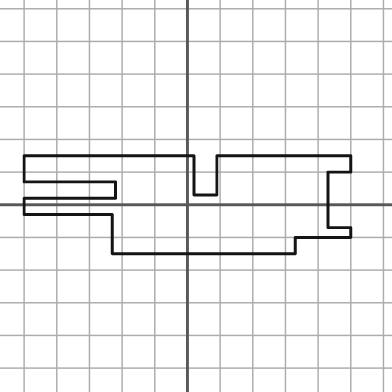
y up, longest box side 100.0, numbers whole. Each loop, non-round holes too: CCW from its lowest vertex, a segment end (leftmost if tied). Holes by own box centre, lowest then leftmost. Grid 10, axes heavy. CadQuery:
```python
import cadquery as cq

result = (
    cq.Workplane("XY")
    .moveTo(-23.0, -15.0)
    .lineTo(33.0, -15.0)
    .lineTo(33.0, -10.0)
    .lineTo(50.0, -10.0)
    .lineTo(50.0, -7.0)
    .lineTo(43.0, -7.0)
    .lineTo(43.0, 10.0)
    .lineTo(50.0, 10.0)
    .lineTo(50.0, 15.0)
    .lineTo(9.0, 15.0)
    .lineTo(9.0, 3.0)
    .lineTo(2.0, 3.0)
    .lineTo(2.0, 15.0)
    .lineTo(-50.0, 15.0)
    .lineTo(-50.0, 7.0)
    .lineTo(-22.0, 7.0)
    .lineTo(-22.0, 2.0)
    .lineTo(-50.0, 2.0)
    .lineTo(-50.0, -3.0)
    .lineTo(-23.0, -3.0)
    .close()
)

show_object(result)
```